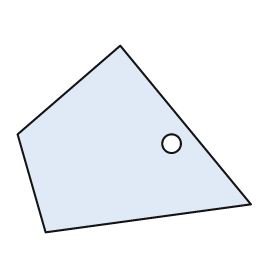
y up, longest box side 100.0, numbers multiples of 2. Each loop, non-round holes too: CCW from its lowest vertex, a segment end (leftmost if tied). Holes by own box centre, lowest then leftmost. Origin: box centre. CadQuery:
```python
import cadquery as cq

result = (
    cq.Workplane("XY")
    .moveTo(-38.0, -40.0)
    .lineTo(50.0, -28.0)
    .lineTo(-6.0, 40.0)
    .lineTo(-50.0, 2.0)
    .close()
    .moveTo(16.0, -2.0)
    .circle(4.0)
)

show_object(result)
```